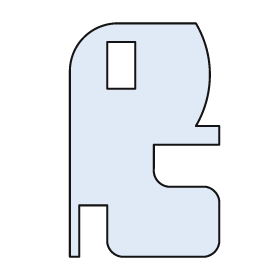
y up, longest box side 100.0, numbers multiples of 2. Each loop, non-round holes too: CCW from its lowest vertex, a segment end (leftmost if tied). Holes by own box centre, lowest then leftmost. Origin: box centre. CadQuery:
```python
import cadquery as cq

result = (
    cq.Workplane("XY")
    .moveTo(-32.0, -50.0)
    .lineTo(-28.0, -50.0)
    .lineTo(-28.0, -28.0)
    .lineTo(-16.0, -28.0)
    .lineTo(-16.0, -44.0)
    .threePointArc((-14.0, -48.0), (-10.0, -50.0))
    .lineTo(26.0, -50.0)
    .threePointArc((30.0, -48.0), (32.0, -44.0))
    .lineTo(32.0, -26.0)
    .threePointArc((30.0, -22.0), (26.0, -20.0))
    .lineTo(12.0, -20.0)
    .threePointArc((6.0, -18.0), (4.0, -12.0))
    .lineTo(4.0, -2.0)
    .lineTo(32.0, -2.0)
    .lineTo(32.0, 6.0)
    .lineTo(22.0, 6.0)
    .threePointArc((28.0, 28.0), (22.0, 50.0))
    .lineTo(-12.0, 50.0)
    .threePointArc((-26.0, 44.0), (-32.0, 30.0))
    .close()
    .moveTo(-16.0, 22.0)
    .lineTo(-4.0, 22.0)
    .lineTo(-4.0, 42.0)
    .lineTo(-16.0, 42.0)
    .close()
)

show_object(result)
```